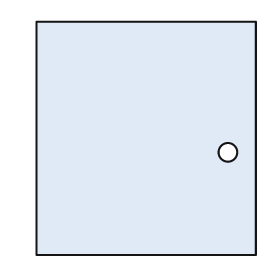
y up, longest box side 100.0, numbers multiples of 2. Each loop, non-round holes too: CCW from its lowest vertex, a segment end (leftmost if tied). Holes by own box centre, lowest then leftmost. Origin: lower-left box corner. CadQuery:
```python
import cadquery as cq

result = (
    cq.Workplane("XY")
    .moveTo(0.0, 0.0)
    .lineTo(94.0, 0.0)
    .lineTo(94.0, 100.0)
    .lineTo(0.0, 100.0)
    .close()
    .moveTo(82.0, 44.0)
    .circle(4.0)
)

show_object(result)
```